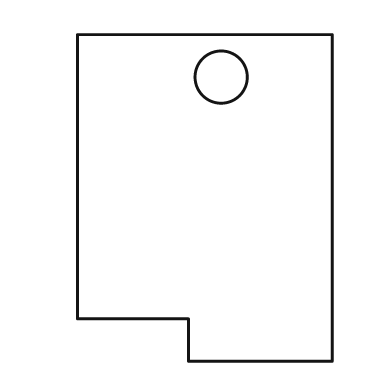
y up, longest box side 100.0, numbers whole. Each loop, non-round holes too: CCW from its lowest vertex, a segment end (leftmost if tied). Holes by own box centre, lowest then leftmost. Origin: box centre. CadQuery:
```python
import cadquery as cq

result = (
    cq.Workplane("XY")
    .moveTo(-5.0, -50.0)
    .lineTo(39.0, -50.0)
    .lineTo(39.0, 50.0)
    .lineTo(-39.0, 50.0)
    .lineTo(-39.0, -37.0)
    .lineTo(-5.0, -37.0)
    .close()
    .moveTo(5.0, 37.0)
    .circle(8.0)
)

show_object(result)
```